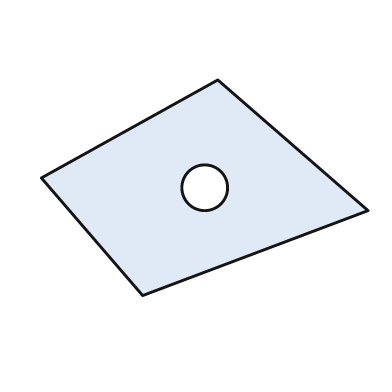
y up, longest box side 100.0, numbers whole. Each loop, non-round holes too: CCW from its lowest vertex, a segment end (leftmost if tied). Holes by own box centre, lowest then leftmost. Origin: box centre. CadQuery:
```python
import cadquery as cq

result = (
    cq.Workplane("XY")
    .moveTo(-19.0, -33.0)
    .lineTo(50.0, -7.0)
    .lineTo(4.0, 33.0)
    .lineTo(-50.0, 3.0)
    .close()
    .moveTo(0.0, 0.0)
    .circle(7.0)
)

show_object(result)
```